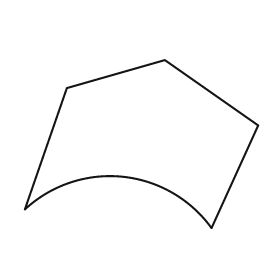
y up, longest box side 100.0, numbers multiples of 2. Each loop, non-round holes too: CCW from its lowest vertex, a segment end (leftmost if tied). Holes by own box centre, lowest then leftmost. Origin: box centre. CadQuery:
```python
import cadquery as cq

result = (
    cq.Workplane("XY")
    .moveTo(30.0, -36.0)
    .lineTo(50.0, 8.0)
    .lineTo(10.0, 36.0)
    .lineTo(-32.0, 24.0)
    .lineTo(-50.0, -28.0)
    .threePointArc((-8.0, -14.0), (30.0, -36.0))
    .close()
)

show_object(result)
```